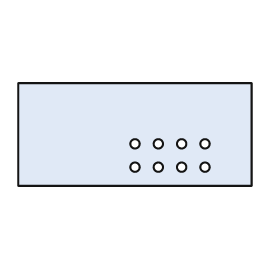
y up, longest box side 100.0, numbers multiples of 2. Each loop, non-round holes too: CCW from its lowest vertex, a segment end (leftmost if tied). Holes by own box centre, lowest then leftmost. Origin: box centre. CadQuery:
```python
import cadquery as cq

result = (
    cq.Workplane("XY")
    .moveTo(-50.0, -22.0)
    .lineTo(50.0, -22.0)
    .lineTo(50.0, 22.0)
    .lineTo(-50.0, 22.0)
    .close()
    .moveTo(0.0, -14.0)
    .circle(2.0)
    .moveTo(10.0, -14.0)
    .circle(2.0)
    .moveTo(20.0, -14.0)
    .circle(2.0)
    .moveTo(30.0, -14.0)
    .circle(2.0)
    .moveTo(0.0, -4.0)
    .circle(2.0)
    .moveTo(10.0, -4.0)
    .circle(2.0)
    .moveTo(20.0, -4.0)
    .circle(2.0)
    .moveTo(30.0, -4.0)
    .circle(2.0)
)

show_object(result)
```